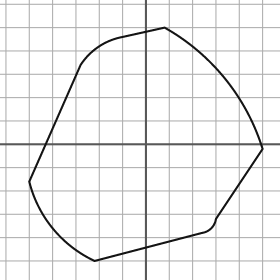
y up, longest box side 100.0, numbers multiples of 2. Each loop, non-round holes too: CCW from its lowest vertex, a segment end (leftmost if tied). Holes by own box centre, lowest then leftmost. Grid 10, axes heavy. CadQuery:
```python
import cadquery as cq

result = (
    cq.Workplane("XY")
    .moveTo(-22.0, -50.0)
    .lineTo(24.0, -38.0)
    .threePointArc((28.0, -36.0), (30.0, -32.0))
    .lineTo(50.0, -2.0)
    .threePointArc((34.0, 28.0), (8.0, 50.0))
    .lineTo(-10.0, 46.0)
    .threePointArc((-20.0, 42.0), (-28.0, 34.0))
    .lineTo(-50.0, -16.0)
    .threePointArc((-40.0, -36.0), (-22.0, -50.0))
    .close()
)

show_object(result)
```